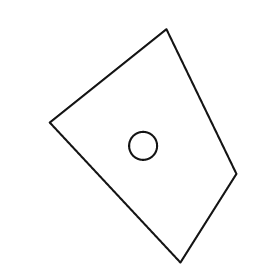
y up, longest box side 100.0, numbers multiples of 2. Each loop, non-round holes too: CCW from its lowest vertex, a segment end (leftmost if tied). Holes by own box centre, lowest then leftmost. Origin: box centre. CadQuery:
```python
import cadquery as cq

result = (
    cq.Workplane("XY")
    .moveTo(16.0, -50.0)
    .lineTo(40.0, -12.0)
    .lineTo(10.0, 50.0)
    .lineTo(-40.0, 10.0)
    .close()
    .moveTo(0.0, 0.0)
    .circle(6.0)
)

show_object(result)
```